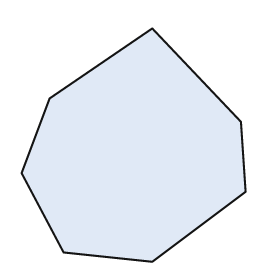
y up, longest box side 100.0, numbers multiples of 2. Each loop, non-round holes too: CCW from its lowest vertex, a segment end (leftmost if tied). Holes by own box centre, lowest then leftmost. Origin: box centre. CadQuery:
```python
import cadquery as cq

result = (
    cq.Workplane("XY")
    .moveTo(8.0, -50.0)
    .lineTo(48.0, -20.0)
    .lineTo(46.0, 10.0)
    .lineTo(8.0, 50.0)
    .lineTo(-36.0, 20.0)
    .lineTo(-48.0, -12.0)
    .lineTo(-30.0, -46.0)
    .close()
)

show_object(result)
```